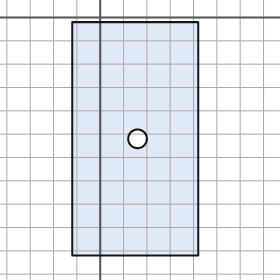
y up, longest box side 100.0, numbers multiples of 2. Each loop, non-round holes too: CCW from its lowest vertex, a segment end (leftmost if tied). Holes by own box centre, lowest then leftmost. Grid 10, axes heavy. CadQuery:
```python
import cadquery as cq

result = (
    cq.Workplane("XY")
    .moveTo(-12.0, -102.0)
    .lineTo(42.0, -102.0)
    .lineTo(42.0, -2.0)
    .lineTo(-12.0, -2.0)
    .close()
    .moveTo(16.0, -52.0)
    .circle(4.0)
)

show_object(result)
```